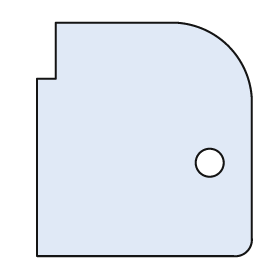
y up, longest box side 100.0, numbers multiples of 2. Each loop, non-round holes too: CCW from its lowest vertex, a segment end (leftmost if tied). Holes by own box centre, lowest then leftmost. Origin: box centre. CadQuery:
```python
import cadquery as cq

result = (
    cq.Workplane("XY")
    .moveTo(-46.0, -50.0)
    .lineTo(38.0, -50.0)
    .threePointArc((44.0, -48.0), (46.0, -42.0))
    .lineTo(46.0, 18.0)
    .threePointArc((36.0, 40.0), (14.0, 50.0))
    .lineTo(-38.0, 50.0)
    .lineTo(-38.0, 26.0)
    .lineTo(-46.0, 26.0)
    .close()
    .moveTo(28.0, -10.0)
    .circle(6.0)
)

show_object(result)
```